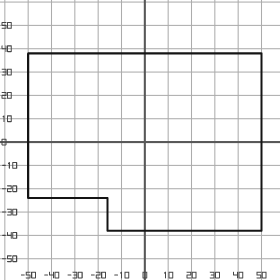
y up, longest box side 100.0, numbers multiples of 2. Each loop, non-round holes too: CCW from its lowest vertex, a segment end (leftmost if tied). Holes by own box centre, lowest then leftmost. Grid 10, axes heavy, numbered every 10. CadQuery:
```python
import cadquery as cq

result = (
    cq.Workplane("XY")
    .moveTo(-16.0, -38.0)
    .lineTo(50.0, -38.0)
    .lineTo(50.0, 38.0)
    .lineTo(-50.0, 38.0)
    .lineTo(-50.0, -24.0)
    .lineTo(-16.0, -24.0)
    .close()
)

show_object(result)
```